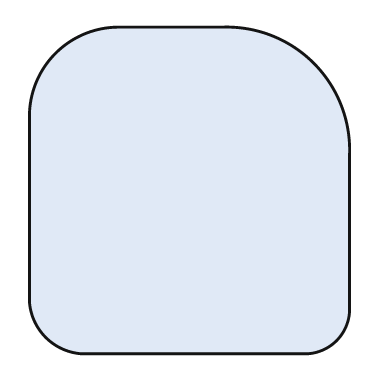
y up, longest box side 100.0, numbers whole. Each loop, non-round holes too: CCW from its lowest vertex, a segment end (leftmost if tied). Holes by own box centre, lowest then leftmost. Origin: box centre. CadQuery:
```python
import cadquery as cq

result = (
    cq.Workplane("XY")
    .moveTo(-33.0, -50.0)
    .lineTo(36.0, -50.0)
    .threePointArc((45.0, -46.0), (49.0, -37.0))
    .lineTo(49.0, 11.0)
    .threePointArc((38.0, 39.0), (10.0, 50.0))
    .lineTo(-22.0, 50.0)
    .threePointArc((-41.0, 42.0), (-49.0, 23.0))
    .lineTo(-49.0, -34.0)
    .threePointArc((-44.0, -45.0), (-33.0, -50.0))
    .close()
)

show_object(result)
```